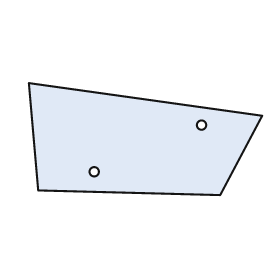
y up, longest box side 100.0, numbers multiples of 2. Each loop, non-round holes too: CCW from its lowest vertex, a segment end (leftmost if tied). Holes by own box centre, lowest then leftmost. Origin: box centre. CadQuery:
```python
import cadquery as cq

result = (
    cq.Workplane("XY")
    .moveTo(32.0, -24.0)
    .lineTo(50.0, 10.0)
    .lineTo(-50.0, 24.0)
    .lineTo(-46.0, -22.0)
    .close()
    .moveTo(-22.0, -14.0)
    .circle(2.0)
    .moveTo(24.0, 6.0)
    .circle(2.0)
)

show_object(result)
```